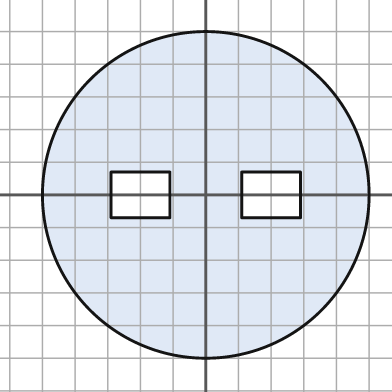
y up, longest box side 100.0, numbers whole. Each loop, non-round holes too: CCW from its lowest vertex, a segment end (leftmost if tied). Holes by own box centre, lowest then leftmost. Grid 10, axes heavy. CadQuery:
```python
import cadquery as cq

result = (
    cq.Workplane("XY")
    .moveTo(0.0, 0.0)
    .circle(50.0)
    .moveTo(-29.0, -7.0)
    .lineTo(-11.0, -7.0)
    .lineTo(-11.0, 7.0)
    .lineTo(-29.0, 7.0)
    .close()
    .moveTo(11.0, -7.0)
    .lineTo(29.0, -7.0)
    .lineTo(29.0, 7.0)
    .lineTo(11.0, 7.0)
    .close()
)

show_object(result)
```